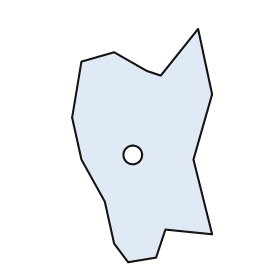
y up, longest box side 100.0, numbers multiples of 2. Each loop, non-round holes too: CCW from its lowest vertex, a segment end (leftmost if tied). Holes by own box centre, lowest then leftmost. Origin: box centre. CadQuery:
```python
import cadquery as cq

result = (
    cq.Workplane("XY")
    .moveTo(-6.0, -50.0)
    .lineTo(6.0, -48.0)
    .lineTo(10.0, -36.0)
    .lineTo(30.0, -38.0)
    .lineTo(22.0, -6.0)
    .lineTo(30.0, 22.0)
    .lineTo(24.0, 50.0)
    .lineTo(8.0, 30.0)
    .lineTo(2.0, 32.0)
    .lineTo(-12.0, 40.0)
    .lineTo(-26.0, 36.0)
    .lineTo(-30.0, 12.0)
    .lineTo(-26.0, -6.0)
    .lineTo(-16.0, -24.0)
    .lineTo(-12.0, -42.0)
    .close()
    .moveTo(-4.0, -4.0)
    .circle(4.0)
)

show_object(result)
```